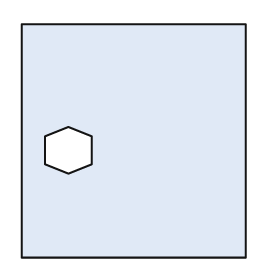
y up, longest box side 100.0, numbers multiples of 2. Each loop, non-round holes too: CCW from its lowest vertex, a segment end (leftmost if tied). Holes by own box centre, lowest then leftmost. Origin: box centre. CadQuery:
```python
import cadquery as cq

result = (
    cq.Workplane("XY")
    .moveTo(-48.0, -50.0)
    .lineTo(48.0, -50.0)
    .lineTo(48.0, 50.0)
    .lineTo(-48.0, 50.0)
    .close()
    .moveTo(-28.0, -14.0)
    .lineTo(-18.0, -10.0)
    .lineTo(-18.0, 2.0)
    .lineTo(-28.0, 6.0)
    .lineTo(-38.0, 2.0)
    .lineTo(-38.0, -10.0)
    .close()
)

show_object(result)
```